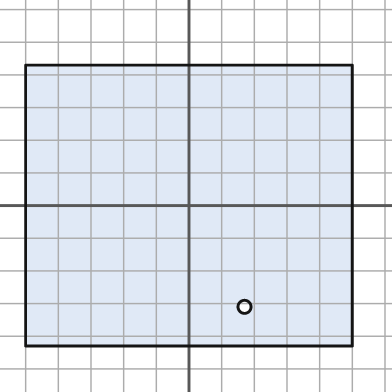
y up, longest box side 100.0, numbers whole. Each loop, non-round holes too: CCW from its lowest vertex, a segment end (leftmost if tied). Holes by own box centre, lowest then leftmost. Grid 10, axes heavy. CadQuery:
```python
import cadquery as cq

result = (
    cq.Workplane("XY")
    .moveTo(-50.0, -43.0)
    .lineTo(50.0, -43.0)
    .lineTo(50.0, 43.0)
    .lineTo(-50.0, 43.0)
    .close()
    .moveTo(17.0, -31.0)
    .circle(2.0)
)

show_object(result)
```